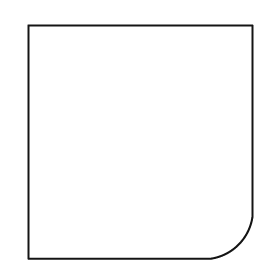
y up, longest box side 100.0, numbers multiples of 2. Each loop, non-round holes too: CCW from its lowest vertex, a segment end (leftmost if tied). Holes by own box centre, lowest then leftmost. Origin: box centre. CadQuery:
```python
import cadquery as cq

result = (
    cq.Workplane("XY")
    .moveTo(-48.0, -50.0)
    .lineTo(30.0, -50.0)
    .threePointArc((42.0, -44.0), (48.0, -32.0))
    .lineTo(48.0, 50.0)
    .lineTo(-48.0, 50.0)
    .close()
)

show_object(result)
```